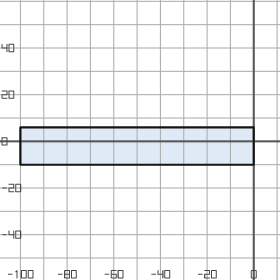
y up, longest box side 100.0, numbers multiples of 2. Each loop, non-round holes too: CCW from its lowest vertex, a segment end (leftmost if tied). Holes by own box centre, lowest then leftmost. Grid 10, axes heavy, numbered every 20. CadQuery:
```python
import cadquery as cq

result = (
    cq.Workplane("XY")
    .moveTo(-100.0, -10.0)
    .lineTo(0.0, -10.0)
    .lineTo(0.0, 6.0)
    .lineTo(-100.0, 6.0)
    .close()
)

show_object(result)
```